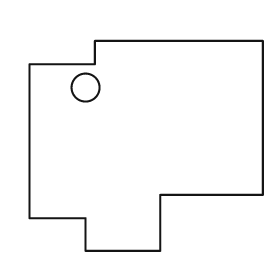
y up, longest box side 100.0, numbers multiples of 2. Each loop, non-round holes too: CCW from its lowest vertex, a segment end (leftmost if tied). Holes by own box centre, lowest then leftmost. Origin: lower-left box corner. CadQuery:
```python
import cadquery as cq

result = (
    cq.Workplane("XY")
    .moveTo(24.0, 0.0)
    .lineTo(56.0, 0.0)
    .lineTo(56.0, 24.0)
    .lineTo(100.0, 24.0)
    .lineTo(100.0, 90.0)
    .lineTo(28.0, 90.0)
    .lineTo(28.0, 80.0)
    .lineTo(0.0, 80.0)
    .lineTo(0.0, 14.0)
    .lineTo(24.0, 14.0)
    .close()
    .moveTo(24.0, 70.0)
    .circle(6.0)
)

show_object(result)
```